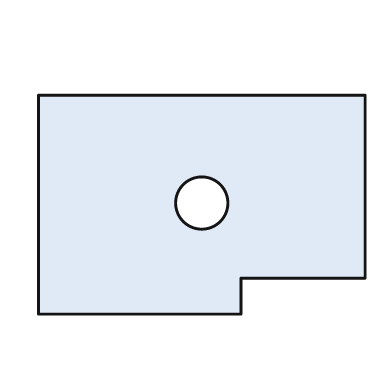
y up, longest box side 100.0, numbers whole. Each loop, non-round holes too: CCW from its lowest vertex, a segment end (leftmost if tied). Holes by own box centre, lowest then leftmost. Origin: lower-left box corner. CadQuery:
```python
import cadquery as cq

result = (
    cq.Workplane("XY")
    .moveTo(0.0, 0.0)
    .lineTo(62.0, 0.0)
    .lineTo(62.0, 11.0)
    .lineTo(100.0, 11.0)
    .lineTo(100.0, 67.0)
    .lineTo(0.0, 67.0)
    .close()
    .moveTo(50.0, 34.0)
    .circle(8.0)
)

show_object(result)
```